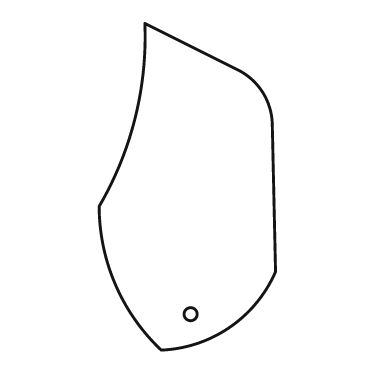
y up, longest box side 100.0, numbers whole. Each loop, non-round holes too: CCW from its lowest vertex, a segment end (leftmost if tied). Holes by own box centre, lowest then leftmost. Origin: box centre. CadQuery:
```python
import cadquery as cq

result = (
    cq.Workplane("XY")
    .moveTo(-8.0, -50.0)
    .threePointArc((13.0, -43.0), (27.0, -26.0))
    .lineTo(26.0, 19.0)
    .threePointArc((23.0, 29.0), (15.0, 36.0))
    .lineTo(-13.0, 50.0)
    .threePointArc((-16.0, 21.0), (-27.0, -6.0))
    .threePointArc((-22.0, -30.0), (-8.0, -50.0))
    .close()
    .moveTo(1.0, -39.0)
    .circle(2.0)
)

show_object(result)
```